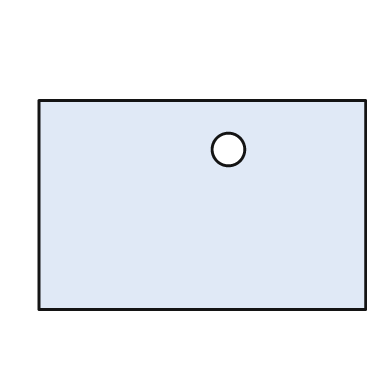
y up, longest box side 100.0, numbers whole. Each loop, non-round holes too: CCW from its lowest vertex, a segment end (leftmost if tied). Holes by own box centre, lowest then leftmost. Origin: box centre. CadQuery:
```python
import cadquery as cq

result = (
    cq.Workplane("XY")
    .moveTo(-50.0, -32.0)
    .lineTo(50.0, -32.0)
    .lineTo(50.0, 32.0)
    .lineTo(-50.0, 32.0)
    .close()
    .moveTo(8.0, 17.0)
    .circle(5.0)
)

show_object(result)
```